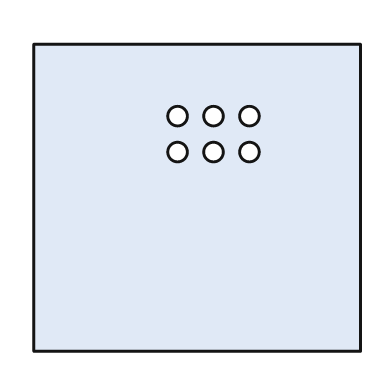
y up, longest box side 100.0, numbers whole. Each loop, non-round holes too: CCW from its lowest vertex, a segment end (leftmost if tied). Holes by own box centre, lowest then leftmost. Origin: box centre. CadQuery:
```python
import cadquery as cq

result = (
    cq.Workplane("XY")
    .moveTo(-50.0, -47.0)
    .lineTo(50.0, -47.0)
    .lineTo(50.0, 47.0)
    .lineTo(-50.0, 47.0)
    .close()
    .moveTo(-6.0, 14.0)
    .circle(3.0)
    .moveTo(5.0, 14.0)
    .circle(3.0)
    .moveTo(16.0, 14.0)
    .circle(3.0)
    .moveTo(-6.0, 25.0)
    .circle(3.0)
    .moveTo(5.0, 25.0)
    .circle(3.0)
    .moveTo(16.0, 25.0)
    .circle(3.0)
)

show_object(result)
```